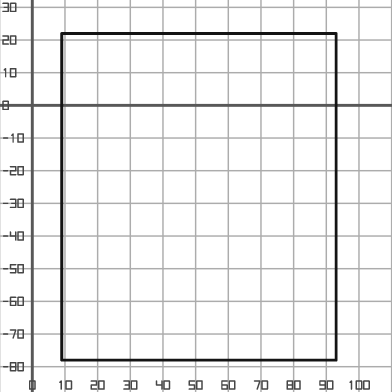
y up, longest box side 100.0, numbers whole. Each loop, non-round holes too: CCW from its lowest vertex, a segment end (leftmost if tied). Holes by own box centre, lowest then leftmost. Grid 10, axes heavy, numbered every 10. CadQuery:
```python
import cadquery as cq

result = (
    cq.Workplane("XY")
    .moveTo(9.0, -78.0)
    .lineTo(93.0, -78.0)
    .lineTo(93.0, 22.0)
    .lineTo(9.0, 22.0)
    .close()
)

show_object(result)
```